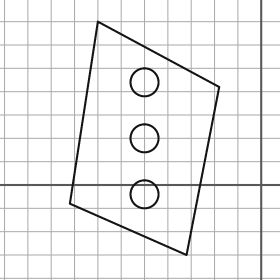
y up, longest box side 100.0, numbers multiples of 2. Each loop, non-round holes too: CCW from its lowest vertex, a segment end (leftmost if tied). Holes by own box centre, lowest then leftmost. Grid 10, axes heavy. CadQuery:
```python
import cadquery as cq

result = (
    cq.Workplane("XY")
    .moveTo(-32.0, -30.0)
    .lineTo(-18.0, 42.0)
    .lineTo(-70.0, 70.0)
    .lineTo(-82.0, -8.0)
    .close()
    .moveTo(-50.0, -4.0)
    .circle(6.0)
    .moveTo(-50.0, 20.0)
    .circle(6.0)
    .moveTo(-50.0, 44.0)
    .circle(6.0)
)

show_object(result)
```